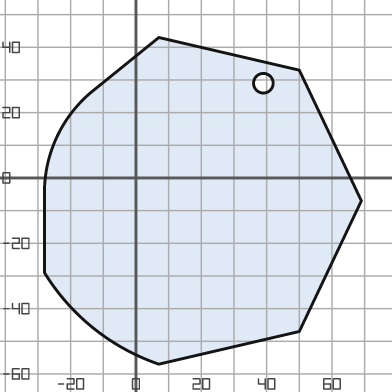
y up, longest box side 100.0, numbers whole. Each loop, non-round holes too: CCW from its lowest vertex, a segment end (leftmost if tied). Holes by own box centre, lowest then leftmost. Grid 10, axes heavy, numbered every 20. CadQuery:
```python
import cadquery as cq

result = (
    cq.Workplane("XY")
    .moveTo(7.0, -57.0)
    .lineTo(50.0, -47.0)
    .lineTo(69.0, -7.0)
    .lineTo(50.0, 33.0)
    .lineTo(7.0, 43.0)
    .lineTo(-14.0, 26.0)
    .threePointArc((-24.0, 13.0), (-28.0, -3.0))
    .lineTo(-28.0, -29.0)
    .threePointArc((-13.0, -46.0), (7.0, -57.0))
    .close()
    .moveTo(39.0, 29.0)
    .circle(3.0)
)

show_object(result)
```